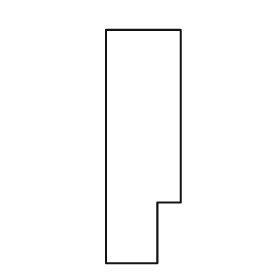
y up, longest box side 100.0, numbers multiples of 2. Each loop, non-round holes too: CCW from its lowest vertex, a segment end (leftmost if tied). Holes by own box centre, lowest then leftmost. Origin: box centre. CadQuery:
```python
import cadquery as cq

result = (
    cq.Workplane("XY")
    .moveTo(-16.0, -50.0)
    .lineTo(6.0, -50.0)
    .lineTo(6.0, -24.0)
    .lineTo(16.0, -24.0)
    .lineTo(16.0, 50.0)
    .lineTo(-16.0, 50.0)
    .close()
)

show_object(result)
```